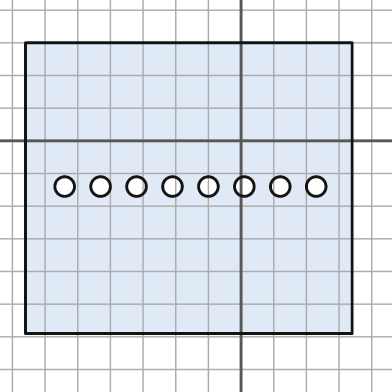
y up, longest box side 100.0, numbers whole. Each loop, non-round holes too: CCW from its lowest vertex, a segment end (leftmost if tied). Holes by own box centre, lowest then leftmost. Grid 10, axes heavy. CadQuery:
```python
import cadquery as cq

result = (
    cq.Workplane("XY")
    .moveTo(-66.0, -59.0)
    .lineTo(34.0, -59.0)
    .lineTo(34.0, 30.0)
    .lineTo(-66.0, 30.0)
    .close()
    .moveTo(-54.0, -14.0)
    .circle(3.0)
    .moveTo(-43.0, -14.0)
    .circle(3.0)
    .moveTo(-32.0, -14.0)
    .circle(3.0)
    .moveTo(-21.0, -14.0)
    .circle(3.0)
    .moveTo(-10.0, -14.0)
    .circle(3.0)
    .moveTo(1.0, -14.0)
    .circle(3.0)
    .moveTo(12.0, -14.0)
    .circle(3.0)
    .moveTo(23.0, -14.0)
    .circle(3.0)
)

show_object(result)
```